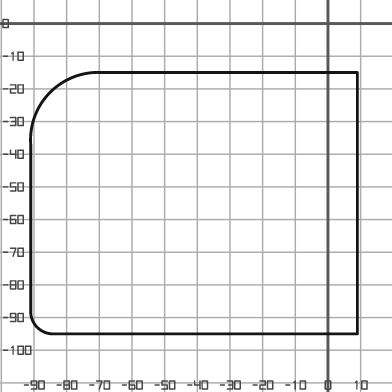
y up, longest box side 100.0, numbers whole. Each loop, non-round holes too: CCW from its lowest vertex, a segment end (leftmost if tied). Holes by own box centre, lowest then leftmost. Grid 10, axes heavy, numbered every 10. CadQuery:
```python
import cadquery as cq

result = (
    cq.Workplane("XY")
    .moveTo(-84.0, -95.0)
    .lineTo(9.0, -95.0)
    .lineTo(9.0, -15.0)
    .lineTo(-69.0, -15.0)
    .threePointArc((-85.0, -21.0), (-91.0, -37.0))
    .lineTo(-91.0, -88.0)
    .threePointArc((-89.0, -93.0), (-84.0, -95.0))
    .close()
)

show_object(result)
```